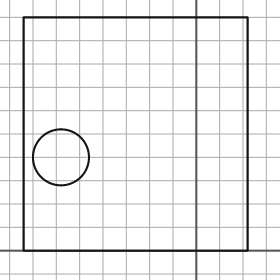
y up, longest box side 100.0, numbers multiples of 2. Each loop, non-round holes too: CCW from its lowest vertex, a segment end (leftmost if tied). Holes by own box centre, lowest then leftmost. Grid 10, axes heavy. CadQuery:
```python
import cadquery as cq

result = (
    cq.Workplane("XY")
    .moveTo(-74.0, 0.0)
    .lineTo(22.0, 0.0)
    .lineTo(22.0, 100.0)
    .lineTo(-74.0, 100.0)
    .close()
    .moveTo(-58.0, 40.0)
    .circle(12.0)
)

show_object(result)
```